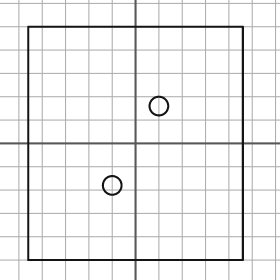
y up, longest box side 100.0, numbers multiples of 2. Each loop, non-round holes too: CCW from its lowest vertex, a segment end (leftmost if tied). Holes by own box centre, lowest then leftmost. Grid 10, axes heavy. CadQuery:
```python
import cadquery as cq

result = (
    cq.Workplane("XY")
    .moveTo(-46.0, -50.0)
    .lineTo(46.0, -50.0)
    .lineTo(46.0, 50.0)
    .lineTo(-46.0, 50.0)
    .close()
    .moveTo(-10.0, -18.0)
    .circle(4.0)
    .moveTo(10.0, 16.0)
    .circle(4.0)
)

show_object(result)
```